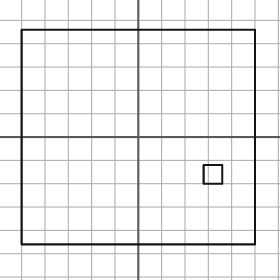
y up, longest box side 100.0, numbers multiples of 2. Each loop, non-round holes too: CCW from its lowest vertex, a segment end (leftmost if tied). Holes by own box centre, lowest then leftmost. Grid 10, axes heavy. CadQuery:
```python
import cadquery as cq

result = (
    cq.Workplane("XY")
    .moveTo(-50.0, -46.0)
    .lineTo(50.0, -46.0)
    .lineTo(50.0, 46.0)
    .lineTo(-50.0, 46.0)
    .close()
    .moveTo(28.0, -20.0)
    .lineTo(36.0, -20.0)
    .lineTo(36.0, -12.0)
    .lineTo(28.0, -12.0)
    .close()
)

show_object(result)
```